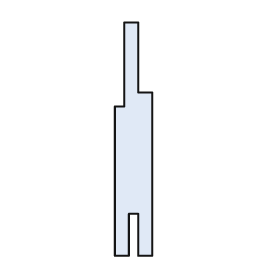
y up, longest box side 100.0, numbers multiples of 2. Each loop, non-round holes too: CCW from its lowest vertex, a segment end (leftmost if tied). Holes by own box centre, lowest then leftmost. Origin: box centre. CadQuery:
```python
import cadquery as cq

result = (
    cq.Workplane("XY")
    .moveTo(-8.0, -50.0)
    .lineTo(-2.0, -50.0)
    .lineTo(-2.0, -32.0)
    .lineTo(2.0, -32.0)
    .lineTo(2.0, -50.0)
    .lineTo(8.0, -50.0)
    .lineTo(8.0, 20.0)
    .lineTo(2.0, 20.0)
    .lineTo(2.0, 50.0)
    .lineTo(-4.0, 50.0)
    .lineTo(-4.0, 14.0)
    .lineTo(-8.0, 14.0)
    .close()
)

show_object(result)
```